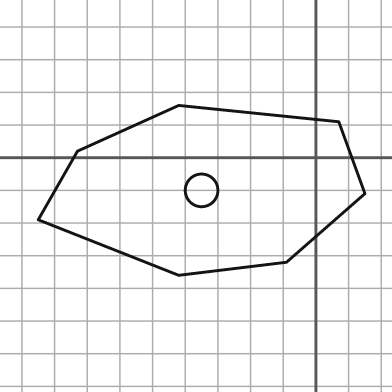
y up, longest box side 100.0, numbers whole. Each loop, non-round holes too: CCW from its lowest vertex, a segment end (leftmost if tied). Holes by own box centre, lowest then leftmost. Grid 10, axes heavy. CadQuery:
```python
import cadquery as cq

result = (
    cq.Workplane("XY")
    .moveTo(-42.0, -36.0)
    .lineTo(-9.0, -32.0)
    .lineTo(15.0, -11.0)
    .lineTo(7.0, 11.0)
    .lineTo(-42.0, 16.0)
    .lineTo(-73.0, 2.0)
    .lineTo(-85.0, -19.0)
    .close()
    .moveTo(-35.0, -10.0)
    .circle(5.0)
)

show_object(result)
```